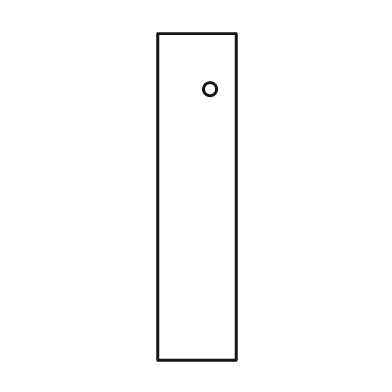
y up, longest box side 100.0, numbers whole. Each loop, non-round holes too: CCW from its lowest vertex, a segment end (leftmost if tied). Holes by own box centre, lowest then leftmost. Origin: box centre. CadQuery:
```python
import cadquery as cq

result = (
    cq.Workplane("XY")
    .moveTo(-12.0, -50.0)
    .lineTo(12.0, -50.0)
    .lineTo(12.0, 50.0)
    .lineTo(-12.0, 50.0)
    .close()
    .moveTo(4.0, 33.0)
    .circle(2.0)
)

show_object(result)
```